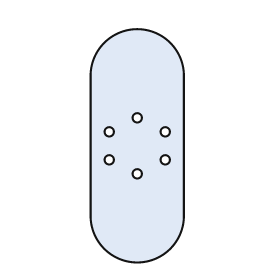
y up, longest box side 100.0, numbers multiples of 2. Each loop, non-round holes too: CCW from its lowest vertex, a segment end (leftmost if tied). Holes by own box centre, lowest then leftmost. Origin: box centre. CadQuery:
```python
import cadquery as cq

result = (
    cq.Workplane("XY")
    .moveTo(-20.0, -30.0)
    .threePointArc((0.0, -50.0), (20.0, -30.0))
    .lineTo(20.0, 30.0)
    .threePointArc((0.0, 50.0), (-20.0, 30.0))
    .close()
    .moveTo(0.0, -12.0)
    .circle(2.0)
    .moveTo(-12.0, -6.0)
    .circle(2.0)
    .moveTo(12.0, -6.0)
    .circle(2.0)
    .moveTo(-12.0, 6.0)
    .circle(2.0)
    .moveTo(12.0, 6.0)
    .circle(2.0)
    .moveTo(0.0, 12.0)
    .circle(2.0)
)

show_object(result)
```